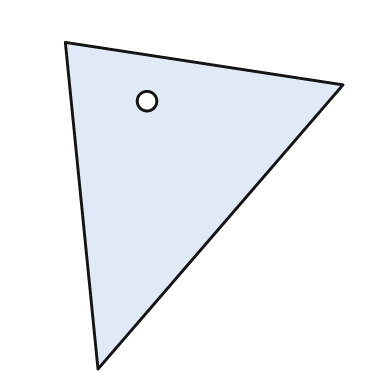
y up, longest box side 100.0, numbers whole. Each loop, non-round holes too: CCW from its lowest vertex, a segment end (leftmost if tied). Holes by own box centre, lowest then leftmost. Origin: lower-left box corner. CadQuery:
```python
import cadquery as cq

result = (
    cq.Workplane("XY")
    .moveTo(10.0, 0.0)
    .lineTo(85.0, 87.0)
    .lineTo(0.0, 100.0)
    .close()
    .moveTo(25.0, 82.0)
    .circle(3.0)
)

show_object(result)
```